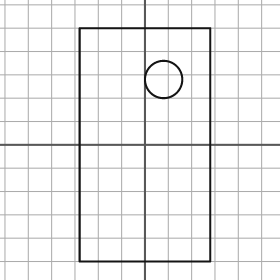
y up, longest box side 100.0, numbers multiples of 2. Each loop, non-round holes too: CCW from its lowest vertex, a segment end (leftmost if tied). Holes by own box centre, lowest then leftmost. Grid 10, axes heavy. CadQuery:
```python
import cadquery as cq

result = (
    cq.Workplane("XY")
    .moveTo(-28.0, -50.0)
    .lineTo(28.0, -50.0)
    .lineTo(28.0, 50.0)
    .lineTo(-28.0, 50.0)
    .close()
    .moveTo(8.0, 28.0)
    .circle(8.0)
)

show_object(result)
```